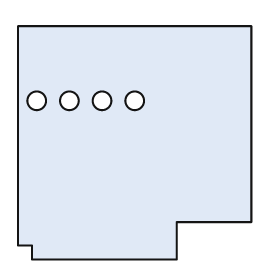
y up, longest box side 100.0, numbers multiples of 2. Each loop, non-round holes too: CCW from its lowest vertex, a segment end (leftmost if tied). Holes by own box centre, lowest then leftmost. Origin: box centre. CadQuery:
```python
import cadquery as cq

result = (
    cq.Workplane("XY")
    .moveTo(-44.0, -50.0)
    .lineTo(18.0, -50.0)
    .lineTo(18.0, -34.0)
    .lineTo(50.0, -34.0)
    .lineTo(50.0, 50.0)
    .lineTo(-50.0, 50.0)
    .lineTo(-50.0, -44.0)
    .lineTo(-44.0, -44.0)
    .close()
    .moveTo(-42.0, 18.0)
    .circle(4.0)
    .moveTo(-28.0, 18.0)
    .circle(4.0)
    .moveTo(-14.0, 18.0)
    .circle(4.0)
    .moveTo(0.0, 18.0)
    .circle(4.0)
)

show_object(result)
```